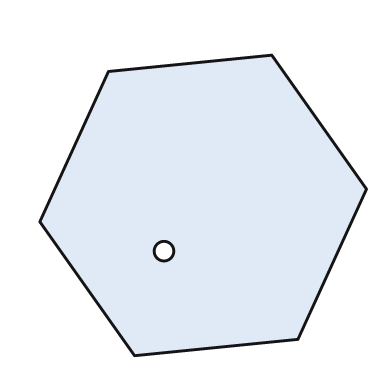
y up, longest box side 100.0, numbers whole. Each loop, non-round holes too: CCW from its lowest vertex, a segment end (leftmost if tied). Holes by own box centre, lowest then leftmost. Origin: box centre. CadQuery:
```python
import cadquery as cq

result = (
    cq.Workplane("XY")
    .moveTo(-21.0, -46.0)
    .lineTo(29.0, -41.0)
    .lineTo(50.0, 5.0)
    .lineTo(21.0, 46.0)
    .lineTo(-29.0, 41.0)
    .lineTo(-50.0, -5.0)
    .close()
    .moveTo(-12.0, -14.0)
    .circle(3.0)
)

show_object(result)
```